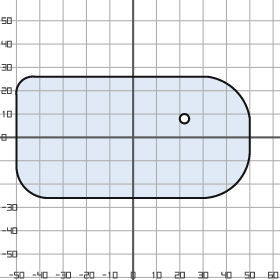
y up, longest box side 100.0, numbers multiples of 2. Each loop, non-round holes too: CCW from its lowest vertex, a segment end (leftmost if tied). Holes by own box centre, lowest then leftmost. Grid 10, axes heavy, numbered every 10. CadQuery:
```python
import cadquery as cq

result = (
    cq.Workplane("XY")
    .moveTo(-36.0, -26.0)
    .lineTo(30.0, -26.0)
    .threePointArc((44.0, -20.0), (50.0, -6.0))
    .lineTo(50.0, 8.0)
    .threePointArc((44.0, 20.0), (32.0, 26.0))
    .lineTo(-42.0, 26.0)
    .threePointArc((-48.0, 24.0), (-50.0, 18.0))
    .lineTo(-50.0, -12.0)
    .threePointArc((-46.0, -22.0), (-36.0, -26.0))
    .close()
    .moveTo(22.0, 8.0)
    .circle(2.0)
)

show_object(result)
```